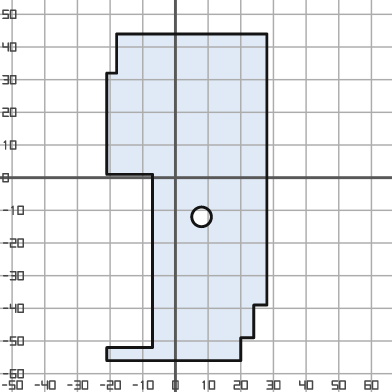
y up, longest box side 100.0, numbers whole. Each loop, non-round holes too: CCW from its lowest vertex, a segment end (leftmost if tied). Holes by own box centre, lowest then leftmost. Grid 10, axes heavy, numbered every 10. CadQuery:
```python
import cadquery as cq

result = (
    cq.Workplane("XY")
    .moveTo(-21.0, -56.0)
    .lineTo(20.0, -56.0)
    .lineTo(20.0, -49.0)
    .lineTo(24.0, -49.0)
    .lineTo(24.0, -39.0)
    .lineTo(28.0, -39.0)
    .lineTo(28.0, 44.0)
    .lineTo(-18.0, 44.0)
    .lineTo(-18.0, 32.0)
    .lineTo(-21.0, 32.0)
    .lineTo(-21.0, 1.0)
    .lineTo(-7.0, 1.0)
    .lineTo(-7.0, -52.0)
    .lineTo(-21.0, -52.0)
    .close()
    .moveTo(8.0, -12.0)
    .circle(3.0)
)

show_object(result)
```